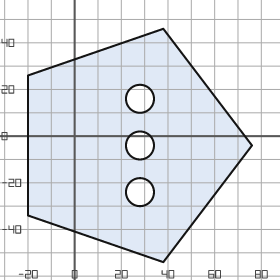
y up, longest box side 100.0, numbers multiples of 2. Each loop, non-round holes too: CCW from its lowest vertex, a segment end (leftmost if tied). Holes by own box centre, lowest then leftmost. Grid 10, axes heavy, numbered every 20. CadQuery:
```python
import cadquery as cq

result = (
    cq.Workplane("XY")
    .moveTo(38.0, -54.0)
    .lineTo(76.0, -4.0)
    .lineTo(38.0, 46.0)
    .lineTo(-20.0, 26.0)
    .lineTo(-20.0, -34.0)
    .close()
    .moveTo(28.0, -24.0)
    .circle(6.0)
    .moveTo(28.0, -4.0)
    .circle(6.0)
    .moveTo(28.0, 16.0)
    .circle(6.0)
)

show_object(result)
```